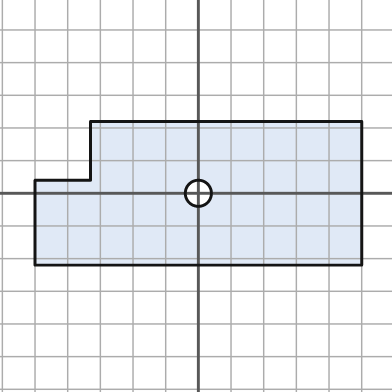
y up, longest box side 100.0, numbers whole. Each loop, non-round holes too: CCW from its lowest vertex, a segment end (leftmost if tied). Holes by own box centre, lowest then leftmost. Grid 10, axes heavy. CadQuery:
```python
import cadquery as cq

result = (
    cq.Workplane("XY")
    .moveTo(-50.0, -22.0)
    .lineTo(50.0, -22.0)
    .lineTo(50.0, 22.0)
    .lineTo(-33.0, 22.0)
    .lineTo(-33.0, 4.0)
    .lineTo(-50.0, 4.0)
    .close()
    .moveTo(0.0, 0.0)
    .circle(4.0)
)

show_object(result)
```